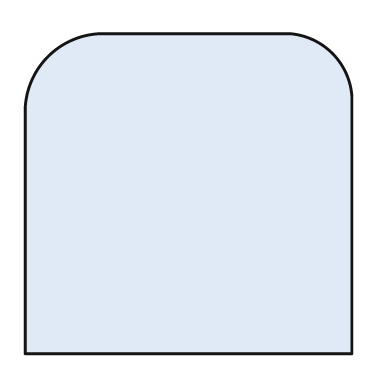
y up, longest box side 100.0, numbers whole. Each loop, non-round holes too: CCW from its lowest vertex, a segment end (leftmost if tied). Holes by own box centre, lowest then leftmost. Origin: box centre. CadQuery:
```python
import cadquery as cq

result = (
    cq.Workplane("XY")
    .moveTo(-50.0, -49.0)
    .lineTo(50.0, -49.0)
    .lineTo(50.0, 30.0)
    .threePointArc((44.0, 43.0), (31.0, 49.0))
    .lineTo(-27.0, 49.0)
    .threePointArc((-43.0, 42.0), (-50.0, 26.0))
    .close()
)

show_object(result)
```